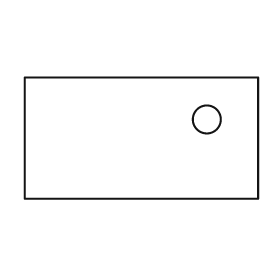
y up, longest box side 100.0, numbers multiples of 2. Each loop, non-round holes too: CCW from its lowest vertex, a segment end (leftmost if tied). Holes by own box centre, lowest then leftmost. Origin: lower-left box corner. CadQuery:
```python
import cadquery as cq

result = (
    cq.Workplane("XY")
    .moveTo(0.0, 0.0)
    .lineTo(100.0, 0.0)
    .lineTo(100.0, 52.0)
    .lineTo(0.0, 52.0)
    .close()
    .moveTo(78.0, 34.0)
    .circle(6.0)
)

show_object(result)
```